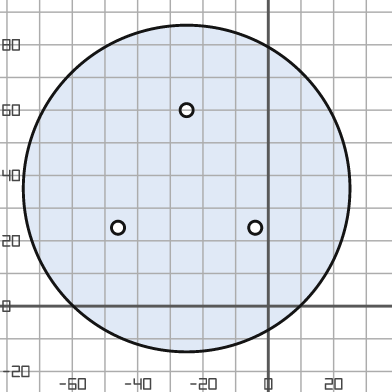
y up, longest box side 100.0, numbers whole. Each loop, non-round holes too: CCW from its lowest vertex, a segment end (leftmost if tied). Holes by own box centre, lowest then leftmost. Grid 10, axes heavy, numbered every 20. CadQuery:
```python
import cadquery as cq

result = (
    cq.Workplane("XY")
    .moveTo(-25.0, 36.0)
    .circle(50.0)
    .moveTo(-46.0, 24.0)
    .circle(2.0)
    .moveTo(-4.0, 24.0)
    .circle(2.0)
    .moveTo(-25.0, 60.0)
    .circle(2.0)
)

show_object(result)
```